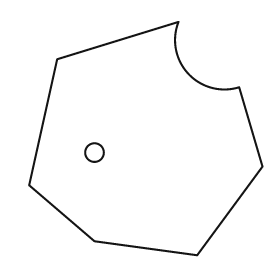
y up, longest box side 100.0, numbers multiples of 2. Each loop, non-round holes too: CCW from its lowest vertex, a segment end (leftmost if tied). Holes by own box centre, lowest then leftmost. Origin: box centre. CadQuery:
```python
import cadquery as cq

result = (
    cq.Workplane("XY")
    .moveTo(22.0, -50.0)
    .lineTo(50.0, -12.0)
    .lineTo(40.0, 22.0)
    .threePointArc((18.0, 28.0), (14.0, 50.0))
    .lineTo(-38.0, 34.0)
    .lineTo(-50.0, -20.0)
    .lineTo(-22.0, -44.0)
    .close()
    .moveTo(-22.0, -6.0)
    .circle(4.0)
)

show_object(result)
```